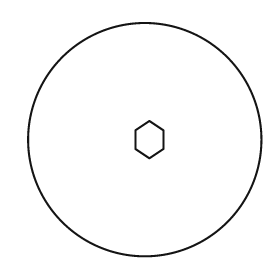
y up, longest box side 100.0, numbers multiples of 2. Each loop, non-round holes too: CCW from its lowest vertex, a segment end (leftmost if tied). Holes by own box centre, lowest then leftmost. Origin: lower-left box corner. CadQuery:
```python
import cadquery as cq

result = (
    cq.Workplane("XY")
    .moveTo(50.0, 50.0)
    .circle(50.0)
    .moveTo(52.0, 42.0)
    .lineTo(58.0, 46.0)
    .lineTo(58.0, 54.0)
    .lineTo(52.0, 58.0)
    .lineTo(46.0, 54.0)
    .lineTo(46.0, 46.0)
    .close()
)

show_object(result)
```